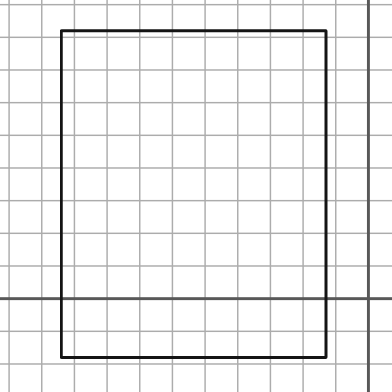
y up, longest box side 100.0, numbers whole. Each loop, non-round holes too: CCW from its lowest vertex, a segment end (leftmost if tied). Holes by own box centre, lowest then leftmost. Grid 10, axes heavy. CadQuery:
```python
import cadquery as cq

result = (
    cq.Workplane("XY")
    .moveTo(-94.0, -18.0)
    .lineTo(-13.0, -18.0)
    .lineTo(-13.0, 82.0)
    .lineTo(-94.0, 82.0)
    .close()
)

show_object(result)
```